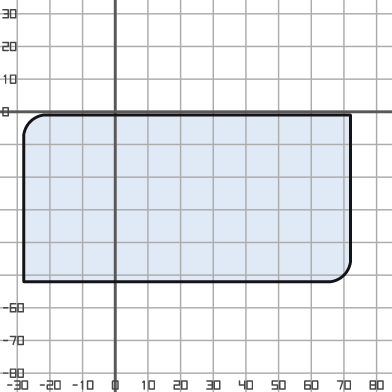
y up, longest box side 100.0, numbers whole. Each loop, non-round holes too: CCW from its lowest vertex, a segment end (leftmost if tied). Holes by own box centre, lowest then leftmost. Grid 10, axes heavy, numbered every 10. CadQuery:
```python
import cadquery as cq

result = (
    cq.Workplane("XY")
    .moveTo(-28.0, -52.0)
    .lineTo(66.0, -52.0)
    .threePointArc((70.0, -50.0), (72.0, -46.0))
    .lineTo(72.0, -1.0)
    .lineTo(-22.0, -1.0)
    .threePointArc((-26.0, -3.0), (-28.0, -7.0))
    .close()
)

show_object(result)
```